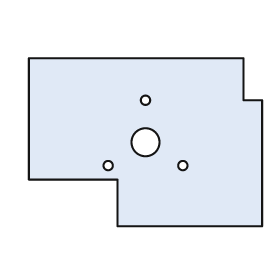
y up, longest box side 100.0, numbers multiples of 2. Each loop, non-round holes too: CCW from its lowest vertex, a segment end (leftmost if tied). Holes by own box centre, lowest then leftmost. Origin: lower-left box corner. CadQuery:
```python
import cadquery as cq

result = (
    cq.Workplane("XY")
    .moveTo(38.0, 0.0)
    .lineTo(100.0, 0.0)
    .lineTo(100.0, 54.0)
    .lineTo(92.0, 54.0)
    .lineTo(92.0, 72.0)
    .lineTo(0.0, 72.0)
    .lineTo(0.0, 20.0)
    .lineTo(38.0, 20.0)
    .close()
    .moveTo(34.0, 26.0)
    .circle(2.0)
    .moveTo(66.0, 26.0)
    .circle(2.0)
    .moveTo(50.0, 36.0)
    .circle(6.0)
    .moveTo(50.0, 54.0)
    .circle(2.0)
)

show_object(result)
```